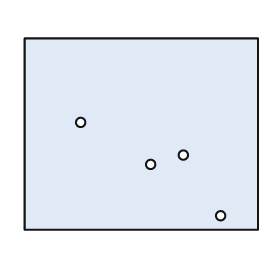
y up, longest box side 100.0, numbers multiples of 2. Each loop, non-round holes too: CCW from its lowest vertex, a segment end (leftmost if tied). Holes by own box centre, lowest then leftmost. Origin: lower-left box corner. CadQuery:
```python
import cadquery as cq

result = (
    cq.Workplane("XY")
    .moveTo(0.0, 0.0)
    .lineTo(100.0, 0.0)
    .lineTo(100.0, 82.0)
    .lineTo(0.0, 82.0)
    .close()
    .moveTo(84.0, 6.0)
    .circle(2.0)
    .moveTo(54.0, 28.0)
    .circle(2.0)
    .moveTo(68.0, 32.0)
    .circle(2.0)
    .moveTo(24.0, 46.0)
    .circle(2.0)
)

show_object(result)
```